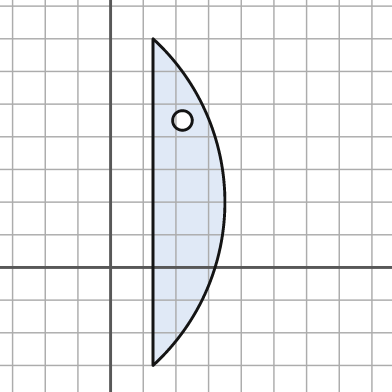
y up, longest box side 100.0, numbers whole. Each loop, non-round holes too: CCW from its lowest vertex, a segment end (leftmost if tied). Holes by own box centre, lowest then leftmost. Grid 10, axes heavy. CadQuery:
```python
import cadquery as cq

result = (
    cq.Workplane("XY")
    .moveTo(13.0, -30.0)
    .threePointArc((35.0, 20.0), (13.0, 70.0))
    .close()
    .moveTo(22.0, 45.0)
    .circle(3.0)
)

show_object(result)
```